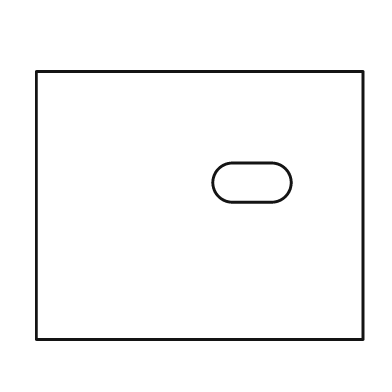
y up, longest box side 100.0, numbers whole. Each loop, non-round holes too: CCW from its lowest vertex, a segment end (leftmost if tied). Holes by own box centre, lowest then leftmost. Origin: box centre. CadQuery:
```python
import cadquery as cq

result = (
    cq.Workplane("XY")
    .moveTo(-50.0, -41.0)
    .lineTo(50.0, -41.0)
    .lineTo(50.0, 41.0)
    .lineTo(-50.0, 41.0)
    .close()
    .moveTo(10.0, 1.0)
    .lineTo(22.0, 1.0)
    .threePointArc((28.0, 7.0), (22.0, 13.0))
    .lineTo(10.0, 13.0)
    .threePointArc((4.0, 7.0), (10.0, 1.0))
    .close()
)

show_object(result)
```